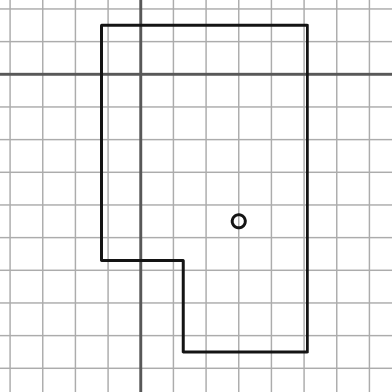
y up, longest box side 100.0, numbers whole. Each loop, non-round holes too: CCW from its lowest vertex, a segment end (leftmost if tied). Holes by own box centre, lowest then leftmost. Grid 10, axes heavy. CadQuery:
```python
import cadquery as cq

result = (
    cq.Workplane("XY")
    .moveTo(13.0, -85.0)
    .lineTo(51.0, -85.0)
    .lineTo(51.0, 15.0)
    .lineTo(-12.0, 15.0)
    .lineTo(-12.0, -57.0)
    .lineTo(13.0, -57.0)
    .close()
    .moveTo(30.0, -45.0)
    .circle(2.0)
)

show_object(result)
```